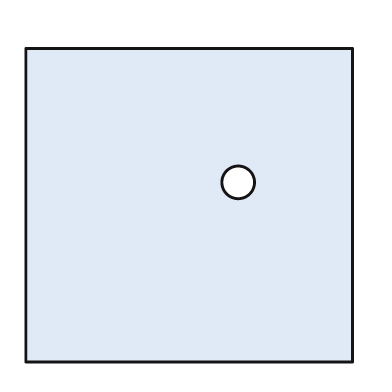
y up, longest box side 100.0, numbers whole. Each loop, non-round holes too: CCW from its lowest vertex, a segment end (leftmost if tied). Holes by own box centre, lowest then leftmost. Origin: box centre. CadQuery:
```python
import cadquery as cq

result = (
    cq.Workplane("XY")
    .moveTo(-50.0, -48.0)
    .lineTo(50.0, -48.0)
    .lineTo(50.0, 48.0)
    .lineTo(-50.0, 48.0)
    .close()
    .moveTo(15.0, 7.0)
    .circle(5.0)
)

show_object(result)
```